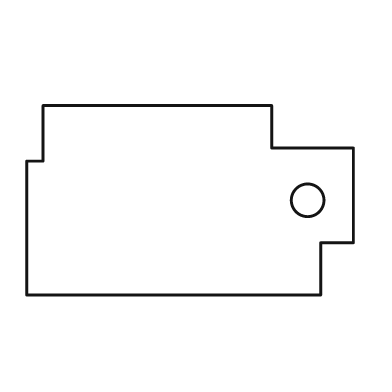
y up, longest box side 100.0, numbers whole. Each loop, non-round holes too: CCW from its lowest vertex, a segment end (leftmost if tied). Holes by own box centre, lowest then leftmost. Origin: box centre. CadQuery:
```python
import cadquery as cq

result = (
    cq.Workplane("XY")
    .moveTo(-50.0, -29.0)
    .lineTo(40.0, -29.0)
    .lineTo(40.0, -13.0)
    .lineTo(50.0, -13.0)
    .lineTo(50.0, 16.0)
    .lineTo(25.0, 16.0)
    .lineTo(25.0, 29.0)
    .lineTo(-45.0, 29.0)
    .lineTo(-45.0, 12.0)
    .lineTo(-50.0, 12.0)
    .close()
    .moveTo(36.0, 0.0)
    .circle(5.0)
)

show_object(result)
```